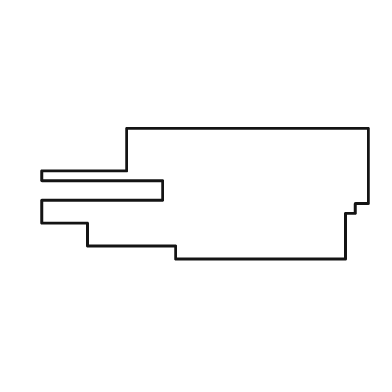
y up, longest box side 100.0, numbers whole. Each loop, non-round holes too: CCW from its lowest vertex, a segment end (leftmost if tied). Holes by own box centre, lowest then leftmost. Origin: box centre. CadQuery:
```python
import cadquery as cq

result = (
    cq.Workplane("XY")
    .moveTo(-9.0, -20.0)
    .lineTo(43.0, -20.0)
    .lineTo(43.0, -6.0)
    .lineTo(46.0, -6.0)
    .lineTo(46.0, -3.0)
    .lineTo(50.0, -3.0)
    .lineTo(50.0, 20.0)
    .lineTo(-24.0, 20.0)
    .lineTo(-24.0, 7.0)
    .lineTo(-50.0, 7.0)
    .lineTo(-50.0, 4.0)
    .lineTo(-13.0, 4.0)
    .lineTo(-13.0, -2.0)
    .lineTo(-50.0, -2.0)
    .lineTo(-50.0, -9.0)
    .lineTo(-36.0, -9.0)
    .lineTo(-36.0, -16.0)
    .lineTo(-9.0, -16.0)
    .close()
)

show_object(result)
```